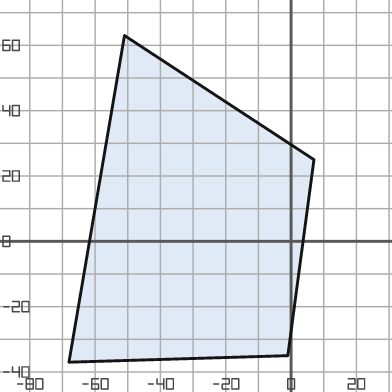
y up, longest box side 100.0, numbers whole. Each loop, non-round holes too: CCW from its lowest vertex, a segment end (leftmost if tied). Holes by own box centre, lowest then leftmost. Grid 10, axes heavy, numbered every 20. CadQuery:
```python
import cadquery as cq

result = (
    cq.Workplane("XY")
    .moveTo(-68.0, -37.0)
    .lineTo(-1.0, -35.0)
    .lineTo(7.0, 25.0)
    .lineTo(-51.0, 63.0)
    .close()
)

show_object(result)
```